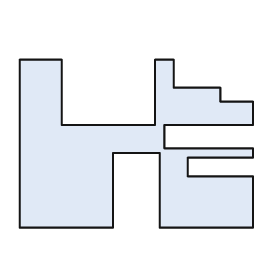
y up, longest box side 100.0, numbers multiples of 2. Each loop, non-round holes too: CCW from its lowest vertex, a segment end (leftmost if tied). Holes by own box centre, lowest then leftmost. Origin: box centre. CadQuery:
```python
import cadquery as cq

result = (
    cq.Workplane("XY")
    .moveTo(-50.0, -36.0)
    .lineTo(-10.0, -36.0)
    .lineTo(-10.0, -4.0)
    .lineTo(10.0, -4.0)
    .lineTo(10.0, -36.0)
    .lineTo(50.0, -36.0)
    .lineTo(50.0, -14.0)
    .lineTo(22.0, -14.0)
    .lineTo(22.0, -6.0)
    .lineTo(50.0, -6.0)
    .lineTo(50.0, -2.0)
    .lineTo(12.0, -2.0)
    .lineTo(12.0, 8.0)
    .lineTo(50.0, 8.0)
    .lineTo(50.0, 18.0)
    .lineTo(36.0, 18.0)
    .lineTo(36.0, 24.0)
    .lineTo(16.0, 24.0)
    .lineTo(16.0, 36.0)
    .lineTo(8.0, 36.0)
    .lineTo(8.0, 8.0)
    .lineTo(-32.0, 8.0)
    .lineTo(-32.0, 36.0)
    .lineTo(-50.0, 36.0)
    .close()
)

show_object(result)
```